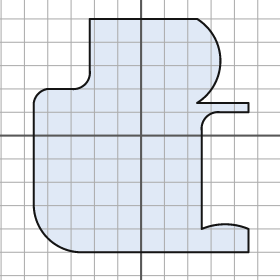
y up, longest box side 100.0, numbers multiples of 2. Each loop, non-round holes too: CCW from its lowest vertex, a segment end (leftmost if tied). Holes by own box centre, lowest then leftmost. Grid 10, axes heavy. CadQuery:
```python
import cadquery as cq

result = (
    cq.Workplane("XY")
    .moveTo(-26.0, -50.0)
    .lineTo(46.0, -50.0)
    .lineTo(46.0, -40.0)
    .threePointArc((36.0, -38.0), (26.0, -40.0))
    .lineTo(26.0, 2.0)
    .threePointArc((28.0, 8.0), (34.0, 10.0))
    .lineTo(46.0, 10.0)
    .lineTo(46.0, 14.0)
    .lineTo(24.0, 14.0)
    .threePointArc((34.0, 32.0), (24.0, 50.0))
    .lineTo(-22.0, 50.0)
    .lineTo(-22.0, 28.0)
    .threePointArc((-24.0, 22.0), (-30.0, 20.0))
    .lineTo(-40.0, 20.0)
    .threePointArc((-44.0, 18.0), (-46.0, 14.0))
    .lineTo(-46.0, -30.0)
    .threePointArc((-40.0, -44.0), (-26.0, -50.0))
    .close()
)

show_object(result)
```